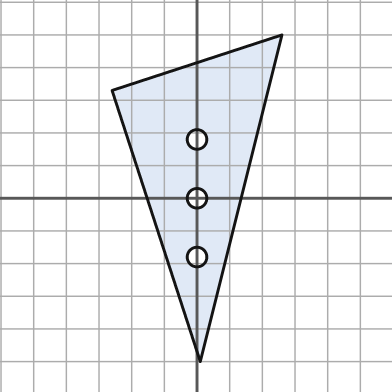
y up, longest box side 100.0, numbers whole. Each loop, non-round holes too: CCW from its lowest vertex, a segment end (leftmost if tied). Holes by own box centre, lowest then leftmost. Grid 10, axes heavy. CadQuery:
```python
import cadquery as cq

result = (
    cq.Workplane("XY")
    .moveTo(1.0, -50.0)
    .lineTo(26.0, 50.0)
    .lineTo(-26.0, 33.0)
    .close()
    .moveTo(0.0, -18.0)
    .circle(3.0)
    .moveTo(0.0, 0.0)
    .circle(3.0)
    .moveTo(0.0, 18.0)
    .circle(3.0)
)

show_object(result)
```